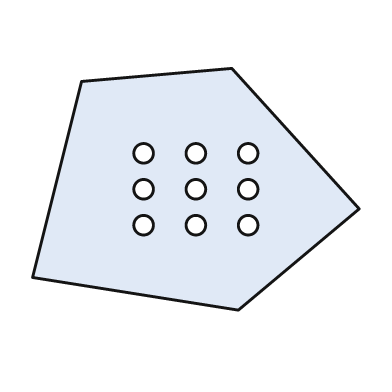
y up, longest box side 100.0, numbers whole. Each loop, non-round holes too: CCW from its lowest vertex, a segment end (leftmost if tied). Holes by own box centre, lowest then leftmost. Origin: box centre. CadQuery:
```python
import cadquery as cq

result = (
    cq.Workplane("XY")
    .moveTo(13.0, -37.0)
    .lineTo(50.0, -6.0)
    .lineTo(11.0, 37.0)
    .lineTo(-35.0, 33.0)
    .lineTo(-50.0, -27.0)
    .close()
    .moveTo(-16.0, -11.0)
    .circle(3.0)
    .moveTo(0.0, -11.0)
    .circle(3.0)
    .moveTo(16.0, -11.0)
    .circle(3.0)
    .moveTo(-16.0, 0.0)
    .circle(3.0)
    .moveTo(0.0, 0.0)
    .circle(3.0)
    .moveTo(16.0, 0.0)
    .circle(3.0)
    .moveTo(-16.0, 11.0)
    .circle(3.0)
    .moveTo(0.0, 11.0)
    .circle(3.0)
    .moveTo(16.0, 11.0)
    .circle(3.0)
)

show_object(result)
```